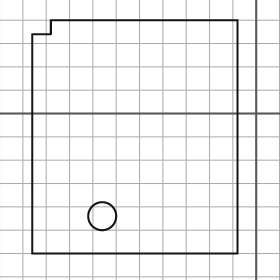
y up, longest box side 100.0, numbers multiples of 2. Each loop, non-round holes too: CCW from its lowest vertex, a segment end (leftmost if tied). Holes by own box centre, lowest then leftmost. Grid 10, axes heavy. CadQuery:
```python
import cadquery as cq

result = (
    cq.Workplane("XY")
    .moveTo(-96.0, -60.0)
    .lineTo(-8.0, -60.0)
    .lineTo(-8.0, 40.0)
    .lineTo(-88.0, 40.0)
    .lineTo(-88.0, 34.0)
    .lineTo(-96.0, 34.0)
    .close()
    .moveTo(-66.0, -44.0)
    .circle(6.0)
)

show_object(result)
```